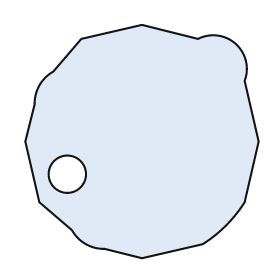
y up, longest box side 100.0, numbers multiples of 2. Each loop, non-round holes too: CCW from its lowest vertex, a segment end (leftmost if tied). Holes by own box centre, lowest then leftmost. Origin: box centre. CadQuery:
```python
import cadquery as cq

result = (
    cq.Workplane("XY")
    .moveTo(0.0, -50.0)
    .lineTo(26.0, -44.0)
    .threePointArc((36.0, -36.0), (44.0, -26.0))
    .lineTo(50.0, 0.0)
    .lineTo(44.0, 26.0)
    .threePointArc((40.0, 42.0), (24.0, 44.0))
    .lineTo(0.0, 50.0)
    .lineTo(-26.0, 44.0)
    .lineTo(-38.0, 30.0)
    .threePointArc((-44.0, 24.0), (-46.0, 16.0))
    .lineTo(-50.0, 0.0)
    .lineTo(-44.0, -26.0)
    .lineTo(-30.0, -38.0)
    .threePointArc((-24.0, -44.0), (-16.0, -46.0))
    .close()
    .moveTo(-32.0, -14.0)
    .circle(8.0)
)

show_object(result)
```